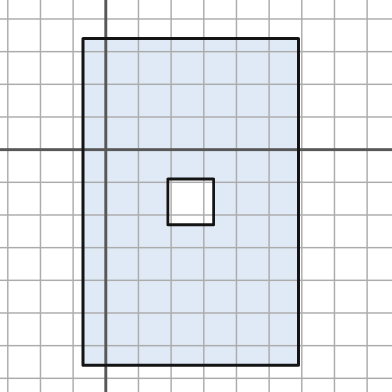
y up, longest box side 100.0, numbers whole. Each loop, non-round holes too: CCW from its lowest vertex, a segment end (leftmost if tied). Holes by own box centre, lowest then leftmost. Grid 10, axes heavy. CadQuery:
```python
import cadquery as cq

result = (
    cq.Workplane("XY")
    .moveTo(-7.0, -66.0)
    .lineTo(59.0, -66.0)
    .lineTo(59.0, 34.0)
    .lineTo(-7.0, 34.0)
    .close()
    .moveTo(19.0, -23.0)
    .lineTo(33.0, -23.0)
    .lineTo(33.0, -9.0)
    .lineTo(19.0, -9.0)
    .close()
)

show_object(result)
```